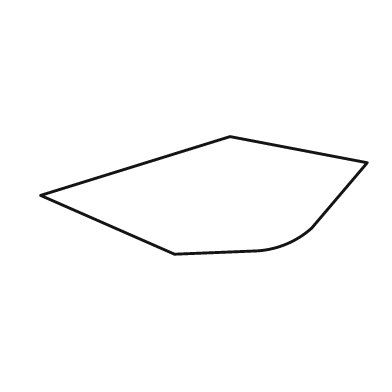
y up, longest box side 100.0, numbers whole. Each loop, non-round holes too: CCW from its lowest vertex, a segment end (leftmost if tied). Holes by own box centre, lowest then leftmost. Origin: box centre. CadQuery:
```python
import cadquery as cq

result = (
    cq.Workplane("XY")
    .moveTo(-9.0, -18.0)
    .lineTo(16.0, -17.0)
    .threePointArc((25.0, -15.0), (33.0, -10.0))
    .lineTo(50.0, 10.0)
    .lineTo(8.0, 18.0)
    .lineTo(-50.0, 0.0)
    .close()
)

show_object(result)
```